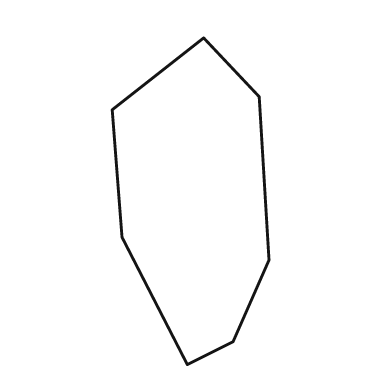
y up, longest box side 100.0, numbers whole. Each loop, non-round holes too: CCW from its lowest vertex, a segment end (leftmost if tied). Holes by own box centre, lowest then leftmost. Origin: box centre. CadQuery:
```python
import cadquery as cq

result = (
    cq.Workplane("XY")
    .moveTo(-1.0, -50.0)
    .lineTo(13.0, -43.0)
    .lineTo(24.0, -18.0)
    .lineTo(21.0, 32.0)
    .lineTo(4.0, 50.0)
    .lineTo(-24.0, 28.0)
    .lineTo(-21.0, -11.0)
    .close()
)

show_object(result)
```